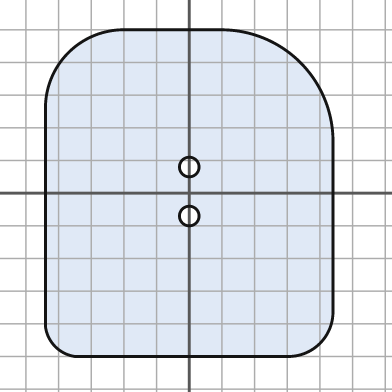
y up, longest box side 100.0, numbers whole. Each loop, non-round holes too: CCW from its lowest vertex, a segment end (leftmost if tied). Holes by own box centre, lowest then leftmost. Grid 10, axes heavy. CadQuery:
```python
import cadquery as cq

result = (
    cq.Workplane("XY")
    .moveTo(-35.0, -50.0)
    .lineTo(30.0, -50.0)
    .threePointArc((40.0, -46.0), (44.0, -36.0))
    .lineTo(44.0, 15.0)
    .threePointArc((34.0, 40.0), (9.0, 50.0))
    .lineTo(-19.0, 50.0)
    .threePointArc((-37.0, 43.0), (-44.0, 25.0))
    .lineTo(-44.0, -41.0)
    .threePointArc((-41.0, -47.0), (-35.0, -50.0))
    .close()
    .moveTo(0.0, -7.0)
    .circle(3.0)
    .moveTo(0.0, 8.0)
    .circle(3.0)
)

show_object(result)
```